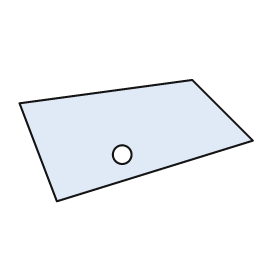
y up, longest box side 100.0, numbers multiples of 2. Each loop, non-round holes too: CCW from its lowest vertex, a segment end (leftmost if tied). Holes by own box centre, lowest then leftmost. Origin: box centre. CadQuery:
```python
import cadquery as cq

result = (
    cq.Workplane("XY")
    .moveTo(-34.0, -26.0)
    .lineTo(50.0, 0.0)
    .lineTo(24.0, 26.0)
    .lineTo(-50.0, 16.0)
    .close()
    .moveTo(-6.0, -6.0)
    .circle(4.0)
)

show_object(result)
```